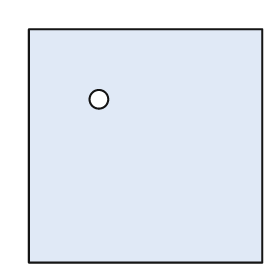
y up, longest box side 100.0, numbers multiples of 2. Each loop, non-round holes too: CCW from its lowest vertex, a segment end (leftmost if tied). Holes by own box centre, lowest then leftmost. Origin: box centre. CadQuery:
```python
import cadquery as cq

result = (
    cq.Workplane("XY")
    .moveTo(-50.0, -50.0)
    .lineTo(50.0, -50.0)
    .lineTo(50.0, 50.0)
    .lineTo(-50.0, 50.0)
    .close()
    .moveTo(-20.0, 20.0)
    .circle(4.0)
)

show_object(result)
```